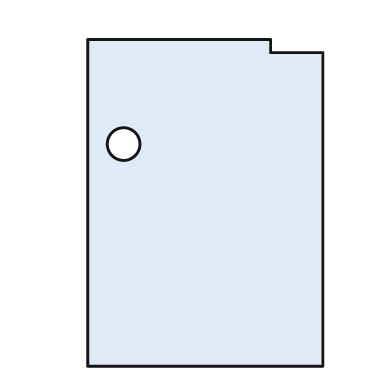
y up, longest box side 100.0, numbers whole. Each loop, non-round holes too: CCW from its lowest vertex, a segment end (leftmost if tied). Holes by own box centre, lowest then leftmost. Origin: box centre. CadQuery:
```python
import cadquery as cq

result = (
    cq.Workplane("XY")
    .moveTo(-36.0, -50.0)
    .lineTo(36.0, -50.0)
    .lineTo(36.0, 46.0)
    .lineTo(20.0, 46.0)
    .lineTo(20.0, 50.0)
    .lineTo(-36.0, 50.0)
    .close()
    .moveTo(-25.0, 18.0)
    .circle(5.0)
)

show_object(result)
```